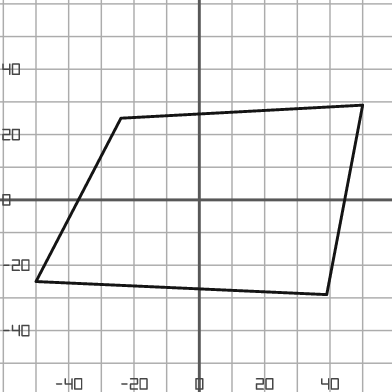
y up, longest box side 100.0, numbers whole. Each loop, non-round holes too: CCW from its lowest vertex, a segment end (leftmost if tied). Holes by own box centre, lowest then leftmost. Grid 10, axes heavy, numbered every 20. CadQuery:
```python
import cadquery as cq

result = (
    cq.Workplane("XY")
    .moveTo(39.0, -29.0)
    .lineTo(50.0, 29.0)
    .lineTo(-24.0, 25.0)
    .lineTo(-50.0, -25.0)
    .close()
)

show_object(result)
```